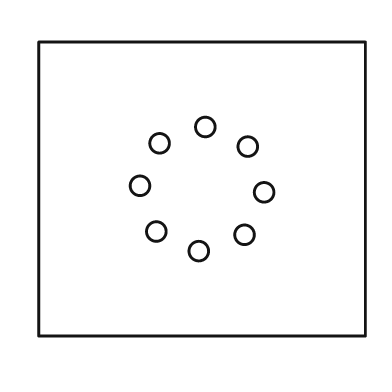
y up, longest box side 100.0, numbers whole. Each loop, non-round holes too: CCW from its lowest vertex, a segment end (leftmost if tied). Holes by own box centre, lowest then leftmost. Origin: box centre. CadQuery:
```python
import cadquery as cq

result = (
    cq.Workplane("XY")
    .moveTo(-50.0, -45.0)
    .lineTo(50.0, -45.0)
    .lineTo(50.0, 45.0)
    .lineTo(-50.0, 45.0)
    .close()
    .moveTo(-1.0, -19.0)
    .circle(3.0)
    .moveTo(13.0, -14.0)
    .circle(3.0)
    .moveTo(-14.0, -13.0)
    .circle(3.0)
    .moveTo(19.0, -1.0)
    .circle(3.0)
    .moveTo(-19.0, 1.0)
    .circle(3.0)
    .moveTo(14.0, 13.0)
    .circle(3.0)
    .moveTo(-13.0, 14.0)
    .circle(3.0)
    .moveTo(1.0, 19.0)
    .circle(3.0)
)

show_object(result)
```